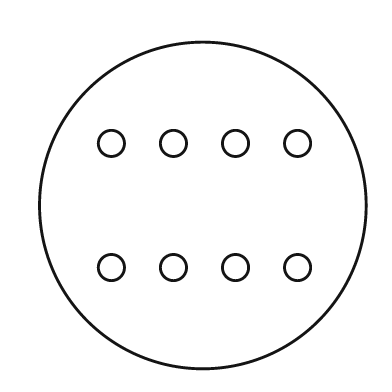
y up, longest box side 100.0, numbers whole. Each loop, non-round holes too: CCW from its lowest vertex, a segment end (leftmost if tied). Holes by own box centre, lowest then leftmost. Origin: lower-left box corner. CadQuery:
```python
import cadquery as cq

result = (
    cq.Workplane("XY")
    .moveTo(50.0, 50.0)
    .circle(50.0)
    .moveTo(22.0, 31.0)
    .circle(4.0)
    .moveTo(41.0, 31.0)
    .circle(4.0)
    .moveTo(60.0, 31.0)
    .circle(4.0)
    .moveTo(79.0, 31.0)
    .circle(4.0)
    .moveTo(22.0, 69.0)
    .circle(4.0)
    .moveTo(41.0, 69.0)
    .circle(4.0)
    .moveTo(60.0, 69.0)
    .circle(4.0)
    .moveTo(79.0, 69.0)
    .circle(4.0)
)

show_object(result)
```